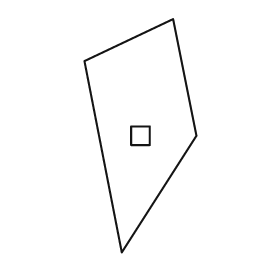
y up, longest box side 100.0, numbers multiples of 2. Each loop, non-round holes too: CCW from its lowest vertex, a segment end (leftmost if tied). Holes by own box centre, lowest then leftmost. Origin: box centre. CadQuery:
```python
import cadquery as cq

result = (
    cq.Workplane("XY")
    .moveTo(-8.0, -50.0)
    .lineTo(24.0, 0.0)
    .lineTo(14.0, 50.0)
    .lineTo(-24.0, 32.0)
    .close()
    .moveTo(-4.0, -4.0)
    .lineTo(4.0, -4.0)
    .lineTo(4.0, 4.0)
    .lineTo(-4.0, 4.0)
    .close()
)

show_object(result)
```